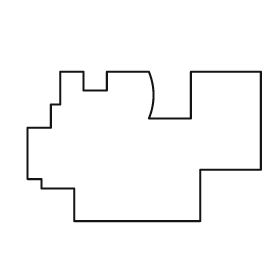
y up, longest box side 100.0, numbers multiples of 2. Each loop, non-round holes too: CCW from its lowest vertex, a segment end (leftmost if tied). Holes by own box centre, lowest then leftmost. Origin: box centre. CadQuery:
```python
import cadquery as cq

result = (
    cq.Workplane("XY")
    .moveTo(-30.0, -32.0)
    .lineTo(24.0, -32.0)
    .lineTo(24.0, -10.0)
    .lineTo(50.0, -10.0)
    .lineTo(50.0, 32.0)
    .lineTo(20.0, 32.0)
    .lineTo(20.0, 12.0)
    .lineTo(2.0, 12.0)
    .threePointArc((4.0, 22.0), (2.0, 32.0))
    .lineTo(-16.0, 32.0)
    .lineTo(-16.0, 24.0)
    .lineTo(-26.0, 24.0)
    .lineTo(-26.0, 32.0)
    .lineTo(-36.0, 32.0)
    .lineTo(-36.0, 18.0)
    .lineTo(-40.0, 18.0)
    .lineTo(-40.0, 8.0)
    .lineTo(-50.0, 8.0)
    .lineTo(-50.0, -14.0)
    .lineTo(-44.0, -14.0)
    .lineTo(-44.0, -18.0)
    .lineTo(-30.0, -18.0)
    .close()
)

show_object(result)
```